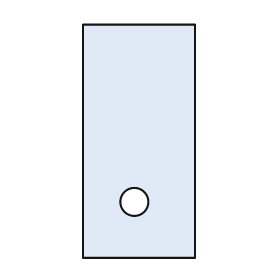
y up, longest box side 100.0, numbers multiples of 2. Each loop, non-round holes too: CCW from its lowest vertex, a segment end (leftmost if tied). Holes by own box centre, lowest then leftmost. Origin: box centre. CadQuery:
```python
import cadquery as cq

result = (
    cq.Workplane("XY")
    .moveTo(-24.0, -50.0)
    .lineTo(24.0, -50.0)
    .lineTo(24.0, 50.0)
    .lineTo(-24.0, 50.0)
    .close()
    .moveTo(-2.0, -26.0)
    .circle(6.0)
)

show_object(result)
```